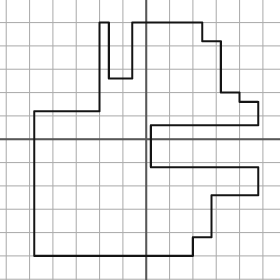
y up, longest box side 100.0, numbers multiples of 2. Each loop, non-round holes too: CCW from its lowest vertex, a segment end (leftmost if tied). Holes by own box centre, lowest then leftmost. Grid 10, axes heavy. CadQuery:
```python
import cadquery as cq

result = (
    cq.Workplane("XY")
    .moveTo(-48.0, -50.0)
    .lineTo(20.0, -50.0)
    .lineTo(20.0, -42.0)
    .lineTo(28.0, -42.0)
    .lineTo(28.0, -24.0)
    .lineTo(48.0, -24.0)
    .lineTo(48.0, -12.0)
    .lineTo(2.0, -12.0)
    .lineTo(2.0, 6.0)
    .lineTo(48.0, 6.0)
    .lineTo(48.0, 16.0)
    .lineTo(40.0, 16.0)
    .lineTo(40.0, 20.0)
    .lineTo(32.0, 20.0)
    .lineTo(32.0, 42.0)
    .lineTo(24.0, 42.0)
    .lineTo(24.0, 50.0)
    .lineTo(-6.0, 50.0)
    .lineTo(-6.0, 26.0)
    .lineTo(-16.0, 26.0)
    .lineTo(-16.0, 50.0)
    .lineTo(-20.0, 50.0)
    .lineTo(-20.0, 12.0)
    .lineTo(-48.0, 12.0)
    .close()
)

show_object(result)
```